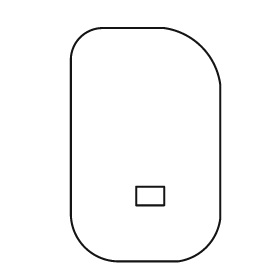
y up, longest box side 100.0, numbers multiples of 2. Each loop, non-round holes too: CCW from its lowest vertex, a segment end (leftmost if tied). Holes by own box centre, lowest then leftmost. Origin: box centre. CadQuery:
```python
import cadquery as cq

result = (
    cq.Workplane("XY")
    .moveTo(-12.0, -50.0)
    .lineTo(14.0, -50.0)
    .threePointArc((26.0, -44.0), (32.0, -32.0))
    .lineTo(32.0, 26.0)
    .threePointArc((24.0, 42.0), (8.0, 50.0))
    .lineTo(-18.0, 50.0)
    .threePointArc((-28.0, 46.0), (-32.0, 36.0))
    .lineTo(-32.0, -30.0)
    .threePointArc((-26.0, -44.0), (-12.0, -50.0))
    .close()
    .moveTo(-4.0, -26.0)
    .lineTo(8.0, -26.0)
    .lineTo(8.0, -18.0)
    .lineTo(-4.0, -18.0)
    .close()
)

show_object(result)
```